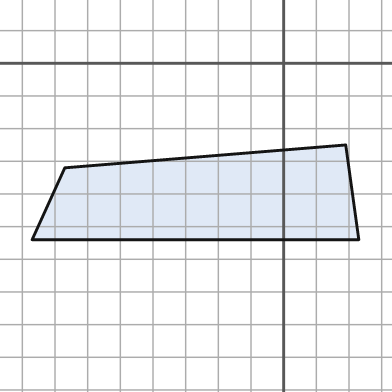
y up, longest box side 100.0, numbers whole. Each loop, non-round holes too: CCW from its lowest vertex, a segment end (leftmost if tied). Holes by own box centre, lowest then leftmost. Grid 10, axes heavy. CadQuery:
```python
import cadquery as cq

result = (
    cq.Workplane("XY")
    .moveTo(-77.0, -54.0)
    .lineTo(23.0, -54.0)
    .lineTo(19.0, -25.0)
    .lineTo(-67.0, -32.0)
    .close()
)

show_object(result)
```